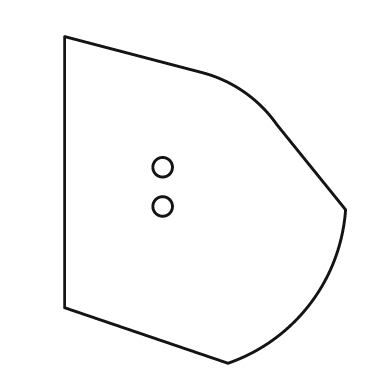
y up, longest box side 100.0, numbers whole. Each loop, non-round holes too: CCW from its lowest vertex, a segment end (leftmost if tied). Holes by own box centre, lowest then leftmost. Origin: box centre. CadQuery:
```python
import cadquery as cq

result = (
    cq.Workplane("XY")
    .moveTo(7.0, -50.0)
    .threePointArc((32.0, -32.0), (43.0, -3.0))
    .lineTo(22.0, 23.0)
    .threePointArc((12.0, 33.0), (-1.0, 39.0))
    .lineTo(-43.0, 50.0)
    .lineTo(-43.0, -33.0)
    .close()
    .moveTo(-13.0, -2.0)
    .circle(3.0)
    .moveTo(-13.0, 10.0)
    .circle(3.0)
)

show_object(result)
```